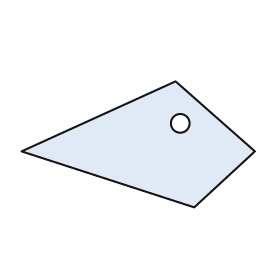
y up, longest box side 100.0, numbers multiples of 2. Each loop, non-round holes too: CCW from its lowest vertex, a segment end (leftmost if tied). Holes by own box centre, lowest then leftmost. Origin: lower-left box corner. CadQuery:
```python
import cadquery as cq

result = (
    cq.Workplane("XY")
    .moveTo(74.0, 0.0)
    .lineTo(100.0, 24.0)
    .lineTo(66.0, 54.0)
    .lineTo(0.0, 24.0)
    .close()
    .moveTo(68.0, 36.0)
    .circle(4.0)
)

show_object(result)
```